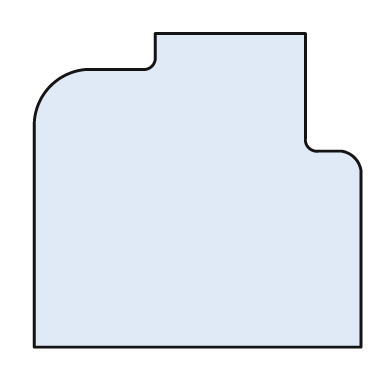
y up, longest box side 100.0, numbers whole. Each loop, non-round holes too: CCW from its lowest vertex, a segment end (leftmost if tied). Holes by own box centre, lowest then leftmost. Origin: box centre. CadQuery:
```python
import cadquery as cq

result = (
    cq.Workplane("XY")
    .moveTo(-50.0, -48.0)
    .lineTo(50.0, -48.0)
    .lineTo(50.0, 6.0)
    .threePointArc((48.0, 10.0), (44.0, 12.0))
    .lineTo(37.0, 12.0)
    .threePointArc((34.0, 13.0), (33.0, 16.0))
    .lineTo(33.0, 48.0)
    .lineTo(-13.0, 48.0)
    .lineTo(-13.0, 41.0)
    .threePointArc((-14.0, 38.0), (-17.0, 37.0))
    .lineTo(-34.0, 37.0)
    .threePointArc((-45.0, 32.0), (-50.0, 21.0))
    .close()
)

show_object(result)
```